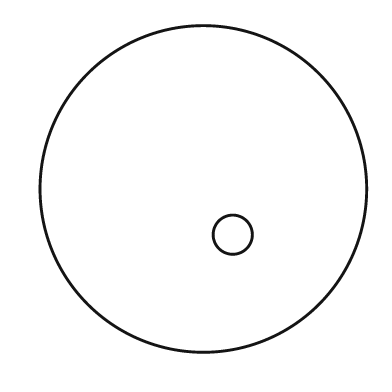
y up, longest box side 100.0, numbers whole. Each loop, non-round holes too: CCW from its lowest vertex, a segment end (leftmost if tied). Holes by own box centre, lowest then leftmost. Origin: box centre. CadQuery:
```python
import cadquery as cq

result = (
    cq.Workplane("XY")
    .moveTo(0.0, 0.0)
    .circle(50.0)
    .moveTo(9.0, -14.0)
    .circle(6.0)
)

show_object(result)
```